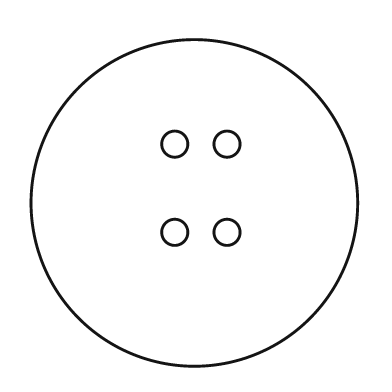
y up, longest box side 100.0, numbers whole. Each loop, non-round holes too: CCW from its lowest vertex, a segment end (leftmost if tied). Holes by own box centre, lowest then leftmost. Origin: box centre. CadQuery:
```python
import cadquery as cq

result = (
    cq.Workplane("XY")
    .moveTo(0.0, 0.0)
    .circle(50.0)
    .moveTo(-6.0, -9.0)
    .circle(4.0)
    .moveTo(10.0, -9.0)
    .circle(4.0)
    .moveTo(-6.0, 18.0)
    .circle(4.0)
    .moveTo(10.0, 18.0)
    .circle(4.0)
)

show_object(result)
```